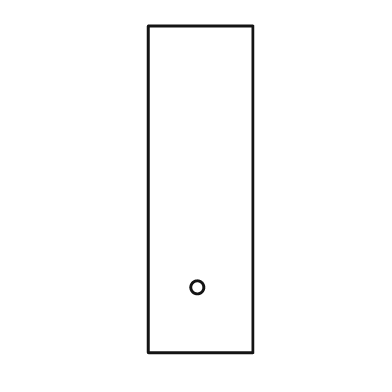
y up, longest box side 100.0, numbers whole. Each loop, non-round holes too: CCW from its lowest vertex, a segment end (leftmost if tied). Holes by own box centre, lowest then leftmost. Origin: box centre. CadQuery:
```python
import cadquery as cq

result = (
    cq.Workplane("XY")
    .moveTo(-16.0, -50.0)
    .lineTo(16.0, -50.0)
    .lineTo(16.0, 50.0)
    .lineTo(-16.0, 50.0)
    .close()
    .moveTo(-1.0, -30.0)
    .circle(2.0)
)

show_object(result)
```